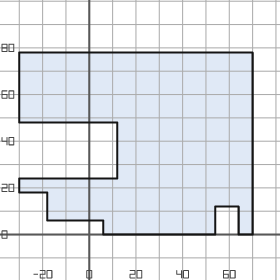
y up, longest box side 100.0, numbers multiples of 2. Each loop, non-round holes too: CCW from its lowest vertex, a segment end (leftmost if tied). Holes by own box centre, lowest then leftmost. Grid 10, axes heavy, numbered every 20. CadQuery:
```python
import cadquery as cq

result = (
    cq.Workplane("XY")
    .moveTo(6.0, 0.0)
    .lineTo(54.0, 0.0)
    .lineTo(54.0, 12.0)
    .lineTo(64.0, 12.0)
    .lineTo(64.0, 0.0)
    .lineTo(70.0, 0.0)
    .lineTo(70.0, 78.0)
    .lineTo(-30.0, 78.0)
    .lineTo(-30.0, 48.0)
    .lineTo(12.0, 48.0)
    .lineTo(12.0, 24.0)
    .lineTo(-30.0, 24.0)
    .lineTo(-30.0, 18.0)
    .lineTo(-18.0, 18.0)
    .lineTo(-18.0, 6.0)
    .lineTo(6.0, 6.0)
    .close()
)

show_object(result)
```